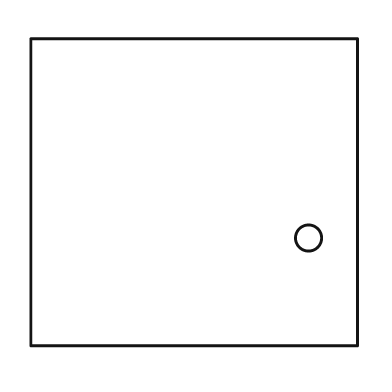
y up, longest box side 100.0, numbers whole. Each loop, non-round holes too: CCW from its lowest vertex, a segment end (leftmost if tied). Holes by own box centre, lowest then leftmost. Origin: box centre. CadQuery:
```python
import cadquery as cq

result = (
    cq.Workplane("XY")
    .moveTo(-50.0, -47.0)
    .lineTo(50.0, -47.0)
    .lineTo(50.0, 47.0)
    .lineTo(-50.0, 47.0)
    .close()
    .moveTo(35.0, -14.0)
    .circle(4.0)
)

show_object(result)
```